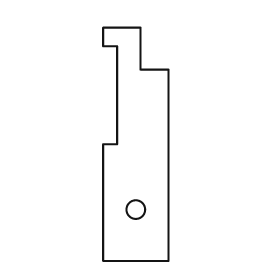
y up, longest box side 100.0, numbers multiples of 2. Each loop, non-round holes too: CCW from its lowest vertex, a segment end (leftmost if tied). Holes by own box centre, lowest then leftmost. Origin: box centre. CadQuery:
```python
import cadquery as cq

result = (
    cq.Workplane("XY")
    .moveTo(-14.0, -50.0)
    .lineTo(14.0, -50.0)
    .lineTo(14.0, 32.0)
    .lineTo(2.0, 32.0)
    .lineTo(2.0, 50.0)
    .lineTo(-14.0, 50.0)
    .lineTo(-14.0, 42.0)
    .lineTo(-8.0, 42.0)
    .lineTo(-8.0, 0.0)
    .lineTo(-14.0, 0.0)
    .close()
    .moveTo(0.0, -28.0)
    .circle(4.0)
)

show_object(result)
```